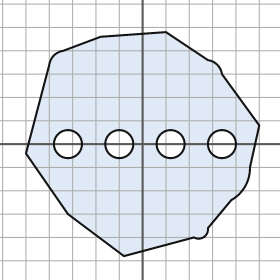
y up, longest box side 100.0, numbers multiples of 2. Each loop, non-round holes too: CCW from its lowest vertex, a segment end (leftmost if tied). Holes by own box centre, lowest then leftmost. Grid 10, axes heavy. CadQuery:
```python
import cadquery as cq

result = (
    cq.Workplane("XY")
    .moveTo(-8.0, -48.0)
    .lineTo(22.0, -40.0)
    .threePointArc((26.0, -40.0), (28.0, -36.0))
    .lineTo(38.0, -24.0)
    .threePointArc((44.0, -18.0), (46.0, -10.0))
    .lineTo(50.0, 8.0)
    .lineTo(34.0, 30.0)
    .threePointArc((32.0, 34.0), (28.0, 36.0))
    .lineTo(10.0, 48.0)
    .lineTo(-18.0, 46.0)
    .lineTo(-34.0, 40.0)
    .threePointArc((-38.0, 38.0), (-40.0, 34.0))
    .lineTo(-50.0, -4.0)
    .lineTo(-32.0, -30.0)
    .close()
    .moveTo(-32.0, 0.0)
    .circle(6.0)
    .moveTo(-10.0, 0.0)
    .circle(6.0)
    .moveTo(12.0, 0.0)
    .circle(6.0)
    .moveTo(34.0, 0.0)
    .circle(6.0)
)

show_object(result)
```